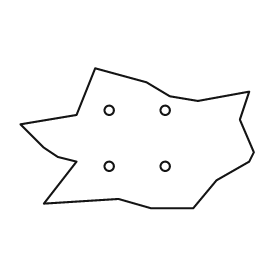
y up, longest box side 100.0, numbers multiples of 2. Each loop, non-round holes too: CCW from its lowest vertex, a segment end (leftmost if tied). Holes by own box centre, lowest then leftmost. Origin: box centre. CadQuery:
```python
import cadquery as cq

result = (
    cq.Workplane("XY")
    .moveTo(6.0, -30.0)
    .lineTo(24.0, -30.0)
    .lineTo(34.0, -18.0)
    .lineTo(48.0, -10.0)
    .lineTo(50.0, -6.0)
    .lineTo(44.0, 8.0)
    .lineTo(48.0, 20.0)
    .lineTo(26.0, 16.0)
    .lineTo(14.0, 18.0)
    .lineTo(4.0, 24.0)
    .lineTo(-18.0, 30.0)
    .lineTo(-26.0, 10.0)
    .lineTo(-50.0, 6.0)
    .lineTo(-40.0, -4.0)
    .lineTo(-34.0, -8.0)
    .lineTo(-26.0, -10.0)
    .lineTo(-40.0, -28.0)
    .lineTo(-8.0, -26.0)
    .close()
    .moveTo(-12.0, -12.0)
    .circle(2.0)
    .moveTo(12.0, -12.0)
    .circle(2.0)
    .moveTo(-12.0, 12.0)
    .circle(2.0)
    .moveTo(12.0, 12.0)
    .circle(2.0)
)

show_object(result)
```